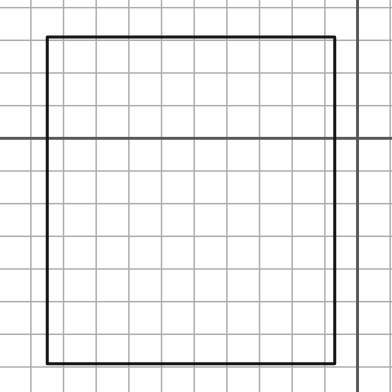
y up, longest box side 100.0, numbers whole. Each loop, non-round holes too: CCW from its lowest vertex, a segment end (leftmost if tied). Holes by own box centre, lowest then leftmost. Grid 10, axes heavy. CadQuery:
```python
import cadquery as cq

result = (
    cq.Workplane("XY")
    .moveTo(-95.0, -69.0)
    .lineTo(-7.0, -69.0)
    .lineTo(-7.0, 31.0)
    .lineTo(-95.0, 31.0)
    .close()
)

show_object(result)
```